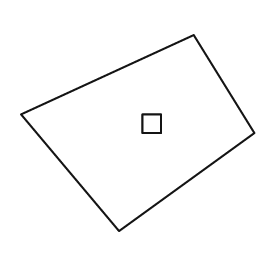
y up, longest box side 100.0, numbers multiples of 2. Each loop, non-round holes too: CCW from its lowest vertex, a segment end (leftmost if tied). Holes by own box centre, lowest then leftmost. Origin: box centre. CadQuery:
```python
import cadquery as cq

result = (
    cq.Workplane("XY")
    .moveTo(-8.0, -42.0)
    .lineTo(50.0, 0.0)
    .lineTo(24.0, 42.0)
    .lineTo(-50.0, 8.0)
    .close()
    .moveTo(2.0, 0.0)
    .lineTo(10.0, 0.0)
    .lineTo(10.0, 8.0)
    .lineTo(2.0, 8.0)
    .close()
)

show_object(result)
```